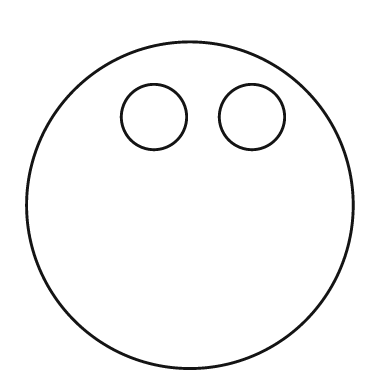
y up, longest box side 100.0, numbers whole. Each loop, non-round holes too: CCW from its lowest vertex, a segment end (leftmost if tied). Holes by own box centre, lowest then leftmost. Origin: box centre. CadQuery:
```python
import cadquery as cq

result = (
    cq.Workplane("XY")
    .moveTo(0.0, 0.0)
    .circle(50.0)
    .moveTo(-11.0, 27.0)
    .circle(10.0)
    .moveTo(19.0, 27.0)
    .circle(10.0)
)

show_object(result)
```